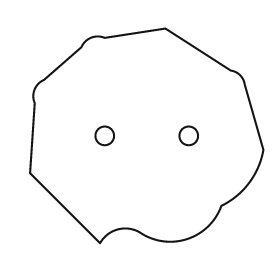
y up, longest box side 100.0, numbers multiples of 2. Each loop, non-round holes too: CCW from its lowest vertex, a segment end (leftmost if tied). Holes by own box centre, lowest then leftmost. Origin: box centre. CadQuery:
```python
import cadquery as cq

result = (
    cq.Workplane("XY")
    .moveTo(-20.0, -46.0)
    .threePointArc((-12.0, -40.0), (-2.0, -42.0))
    .threePointArc((18.0, -44.0), (32.0, -30.0))
    .threePointArc((44.0, -20.0), (50.0, -6.0))
    .lineTo(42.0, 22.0)
    .threePointArc((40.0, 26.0), (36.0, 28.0))
    .lineTo(8.0, 46.0)
    .lineTo(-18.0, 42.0)
    .threePointArc((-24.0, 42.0), (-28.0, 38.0))
    .lineTo(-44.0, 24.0)
    .threePointArc((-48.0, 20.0), (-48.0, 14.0))
    .lineTo(-50.0, -16.0)
    .close()
    .moveTo(-18.0, 0.0)
    .circle(4.0)
    .moveTo(18.0, 0.0)
    .circle(4.0)
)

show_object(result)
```